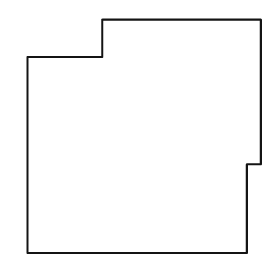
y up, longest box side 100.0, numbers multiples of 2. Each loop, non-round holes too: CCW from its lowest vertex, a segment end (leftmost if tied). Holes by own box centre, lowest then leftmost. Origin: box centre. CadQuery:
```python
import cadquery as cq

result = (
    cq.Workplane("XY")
    .moveTo(-50.0, -50.0)
    .lineTo(44.0, -50.0)
    .lineTo(44.0, -12.0)
    .lineTo(50.0, -12.0)
    .lineTo(50.0, 50.0)
    .lineTo(-18.0, 50.0)
    .lineTo(-18.0, 34.0)
    .lineTo(-50.0, 34.0)
    .close()
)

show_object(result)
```